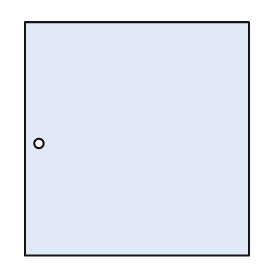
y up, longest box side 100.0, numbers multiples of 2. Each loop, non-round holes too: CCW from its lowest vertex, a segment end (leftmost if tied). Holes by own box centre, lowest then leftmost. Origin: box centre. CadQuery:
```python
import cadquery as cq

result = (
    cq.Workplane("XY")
    .moveTo(-48.0, -50.0)
    .lineTo(48.0, -50.0)
    .lineTo(48.0, 50.0)
    .lineTo(-48.0, 50.0)
    .close()
    .moveTo(-42.0, -2.0)
    .circle(2.0)
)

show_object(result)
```